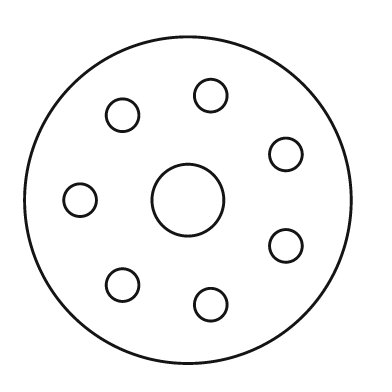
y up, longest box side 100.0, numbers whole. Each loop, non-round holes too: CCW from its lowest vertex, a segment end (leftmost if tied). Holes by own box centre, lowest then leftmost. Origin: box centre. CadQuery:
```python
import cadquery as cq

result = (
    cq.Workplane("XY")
    .moveTo(0.0, 0.0)
    .circle(50.0)
    .moveTo(7.0, -32.0)
    .circle(5.0)
    .moveTo(-20.0, -26.0)
    .circle(5.0)
    .moveTo(30.0, -14.0)
    .circle(5.0)
    .moveTo(-33.0, 0.0)
    .circle(5.0)
    .moveTo(0.0, 0.0)
    .circle(11.0)
    .moveTo(30.0, 14.0)
    .circle(5.0)
    .moveTo(-20.0, 26.0)
    .circle(5.0)
    .moveTo(7.0, 32.0)
    .circle(5.0)
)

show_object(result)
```